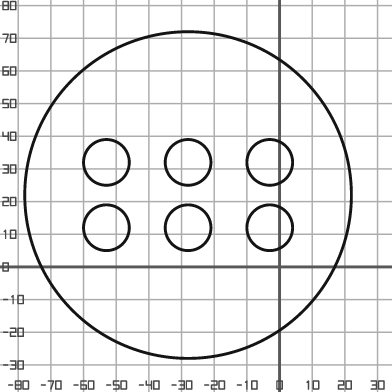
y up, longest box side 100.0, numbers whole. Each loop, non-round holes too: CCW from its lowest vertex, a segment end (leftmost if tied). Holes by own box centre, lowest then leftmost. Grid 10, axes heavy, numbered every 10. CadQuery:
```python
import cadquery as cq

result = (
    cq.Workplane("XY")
    .moveTo(-28.0, 22.0)
    .circle(50.0)
    .moveTo(-53.0, 12.0)
    .circle(7.0)
    .moveTo(-28.0, 12.0)
    .circle(7.0)
    .moveTo(-3.0, 12.0)
    .circle(7.0)
    .moveTo(-53.0, 32.0)
    .circle(7.0)
    .moveTo(-28.0, 32.0)
    .circle(7.0)
    .moveTo(-3.0, 32.0)
    .circle(7.0)
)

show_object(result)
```